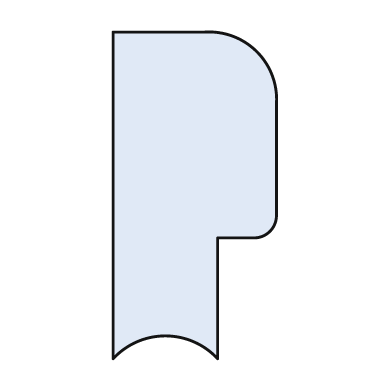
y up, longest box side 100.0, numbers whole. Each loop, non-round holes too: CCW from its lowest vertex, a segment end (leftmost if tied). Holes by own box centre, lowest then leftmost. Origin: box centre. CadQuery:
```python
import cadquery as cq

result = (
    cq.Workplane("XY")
    .moveTo(-25.0, -50.0)
    .threePointArc((-9.0, -43.0), (7.0, -50.0))
    .lineTo(7.0, -13.0)
    .lineTo(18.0, -13.0)
    .threePointArc((23.0, -11.0), (25.0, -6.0))
    .lineTo(25.0, 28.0)
    .threePointArc((19.0, 44.0), (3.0, 50.0))
    .lineTo(-25.0, 50.0)
    .close()
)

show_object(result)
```